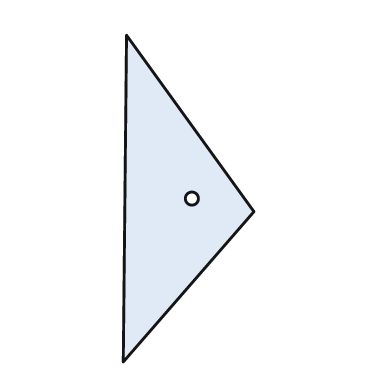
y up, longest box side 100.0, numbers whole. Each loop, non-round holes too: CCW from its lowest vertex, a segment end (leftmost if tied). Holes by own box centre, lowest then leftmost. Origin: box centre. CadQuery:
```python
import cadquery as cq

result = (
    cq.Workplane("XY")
    .moveTo(-20.0, -50.0)
    .lineTo(20.0, -4.0)
    .lineTo(-19.0, 50.0)
    .close()
    .moveTo(1.0, 0.0)
    .circle(2.0)
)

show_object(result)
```